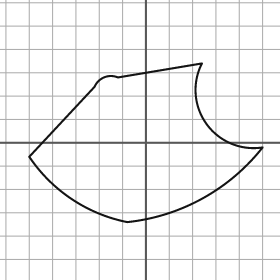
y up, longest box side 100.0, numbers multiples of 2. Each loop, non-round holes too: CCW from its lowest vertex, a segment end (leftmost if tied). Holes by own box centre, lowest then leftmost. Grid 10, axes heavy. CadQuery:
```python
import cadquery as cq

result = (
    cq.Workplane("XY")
    .moveTo(-8.0, -34.0)
    .threePointArc((24.0, -24.0), (50.0, -2.0))
    .threePointArc((26.0, 8.0), (24.0, 34.0))
    .lineTo(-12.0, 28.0)
    .threePointArc((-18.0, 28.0), (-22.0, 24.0))
    .lineTo(-50.0, -6.0)
    .threePointArc((-32.0, -24.0), (-8.0, -34.0))
    .close()
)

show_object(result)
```